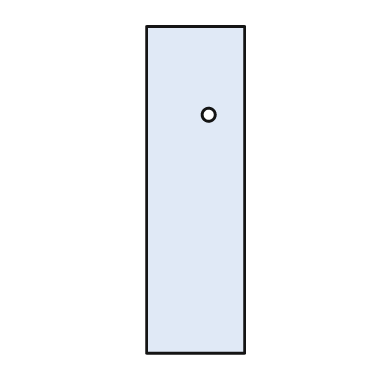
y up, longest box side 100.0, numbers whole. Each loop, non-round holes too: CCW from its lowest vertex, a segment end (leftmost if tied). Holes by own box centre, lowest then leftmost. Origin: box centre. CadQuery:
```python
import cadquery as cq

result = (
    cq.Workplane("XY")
    .moveTo(-15.0, -50.0)
    .lineTo(15.0, -50.0)
    .lineTo(15.0, 50.0)
    .lineTo(-15.0, 50.0)
    .close()
    .moveTo(4.0, 23.0)
    .circle(2.0)
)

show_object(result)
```